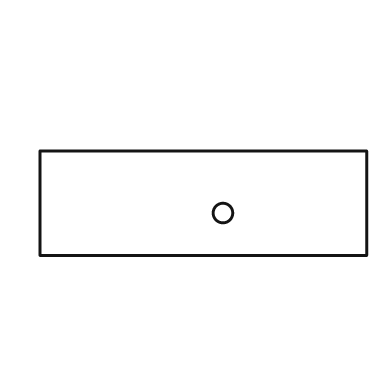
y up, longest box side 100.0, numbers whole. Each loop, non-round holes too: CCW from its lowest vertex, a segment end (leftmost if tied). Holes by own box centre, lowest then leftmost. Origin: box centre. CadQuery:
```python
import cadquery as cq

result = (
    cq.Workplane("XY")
    .moveTo(-50.0, -16.0)
    .lineTo(50.0, -16.0)
    .lineTo(50.0, 16.0)
    .lineTo(-50.0, 16.0)
    .close()
    .moveTo(6.0, -3.0)
    .circle(3.0)
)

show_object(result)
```